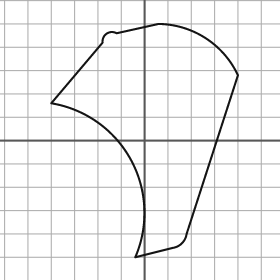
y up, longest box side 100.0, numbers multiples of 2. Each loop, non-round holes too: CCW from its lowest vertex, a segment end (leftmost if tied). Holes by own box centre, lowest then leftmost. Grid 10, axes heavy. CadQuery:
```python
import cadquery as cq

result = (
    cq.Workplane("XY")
    .moveTo(-4.0, -50.0)
    .lineTo(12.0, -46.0)
    .threePointArc((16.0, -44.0), (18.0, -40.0))
    .lineTo(40.0, 28.0)
    .threePointArc((26.0, 44.0), (6.0, 50.0))
    .lineTo(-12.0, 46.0)
    .threePointArc((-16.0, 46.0), (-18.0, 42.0))
    .lineTo(-40.0, 16.0)
    .threePointArc((-6.0, -8.0), (-4.0, -50.0))
    .close()
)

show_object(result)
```